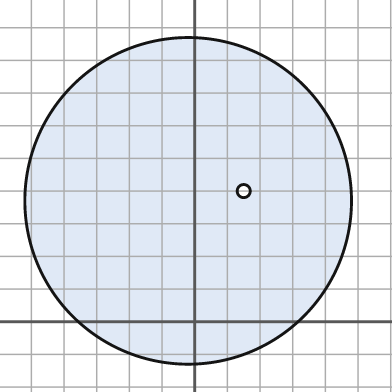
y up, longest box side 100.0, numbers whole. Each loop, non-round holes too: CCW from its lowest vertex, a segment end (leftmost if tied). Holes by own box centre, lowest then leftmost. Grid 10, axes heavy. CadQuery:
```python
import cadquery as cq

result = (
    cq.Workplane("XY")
    .moveTo(-2.0, 37.0)
    .circle(50.0)
    .moveTo(15.0, 40.0)
    .circle(2.0)
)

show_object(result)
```